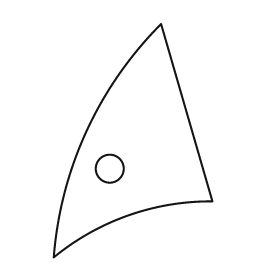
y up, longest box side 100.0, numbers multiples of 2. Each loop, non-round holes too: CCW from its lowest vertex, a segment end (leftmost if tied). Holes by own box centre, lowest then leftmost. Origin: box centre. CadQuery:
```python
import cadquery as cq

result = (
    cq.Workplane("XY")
    .moveTo(-34.0, -50.0)
    .threePointArc((-2.0, -32.0), (34.0, -26.0))
    .lineTo(12.0, 50.0)
    .threePointArc((-20.0, 4.0), (-34.0, -50.0))
    .close()
    .moveTo(-10.0, -12.0)
    .circle(6.0)
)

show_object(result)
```